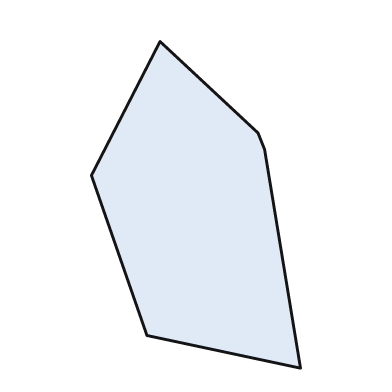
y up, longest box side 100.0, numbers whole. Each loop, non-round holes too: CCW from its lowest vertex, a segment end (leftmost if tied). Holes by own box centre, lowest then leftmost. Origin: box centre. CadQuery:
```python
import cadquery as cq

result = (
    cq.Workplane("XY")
    .moveTo(32.0, -50.0)
    .lineTo(21.0, 17.0)
    .lineTo(19.0, 22.0)
    .lineTo(-11.0, 50.0)
    .lineTo(-32.0, 9.0)
    .lineTo(-15.0, -40.0)
    .close()
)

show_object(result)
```